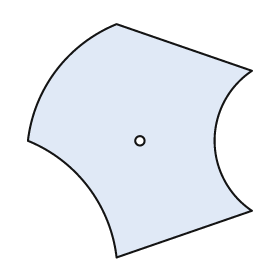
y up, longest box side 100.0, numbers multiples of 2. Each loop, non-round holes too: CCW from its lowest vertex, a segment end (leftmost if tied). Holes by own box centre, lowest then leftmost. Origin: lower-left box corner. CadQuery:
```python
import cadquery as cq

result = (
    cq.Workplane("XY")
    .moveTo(38.0, 0.0)
    .lineTo(96.0, 20.0)
    .threePointArc((80.0, 50.0), (96.0, 80.0))
    .lineTo(38.0, 100.0)
    .threePointArc((12.0, 80.0), (0.0, 50.0))
    .threePointArc((26.0, 30.0), (38.0, 0.0))
    .close()
    .moveTo(48.0, 50.0)
    .circle(2.0)
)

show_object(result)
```